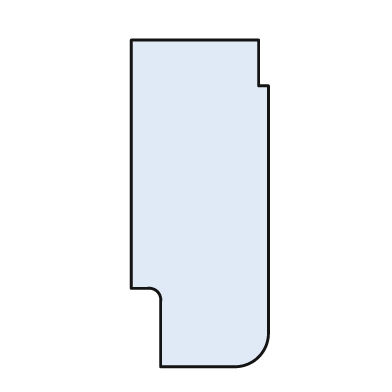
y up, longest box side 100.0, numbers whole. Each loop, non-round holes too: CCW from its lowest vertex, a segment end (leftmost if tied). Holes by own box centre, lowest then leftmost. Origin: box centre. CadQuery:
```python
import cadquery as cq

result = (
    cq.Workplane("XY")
    .moveTo(-12.0, -50.0)
    .lineTo(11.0, -50.0)
    .threePointArc((18.0, -47.0), (21.0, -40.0))
    .lineTo(21.0, 36.0)
    .lineTo(18.0, 36.0)
    .lineTo(18.0, 50.0)
    .lineTo(-21.0, 50.0)
    .lineTo(-21.0, -26.0)
    .lineTo(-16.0, -26.0)
    .threePointArc((-13.0, -27.0), (-12.0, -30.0))
    .close()
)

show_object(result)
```